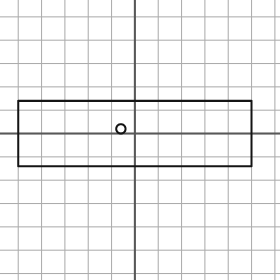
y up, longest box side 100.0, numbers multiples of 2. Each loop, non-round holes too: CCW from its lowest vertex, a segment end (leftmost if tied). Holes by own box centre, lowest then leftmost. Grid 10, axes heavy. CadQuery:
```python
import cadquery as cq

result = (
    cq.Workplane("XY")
    .moveTo(-50.0, -14.0)
    .lineTo(50.0, -14.0)
    .lineTo(50.0, 14.0)
    .lineTo(-50.0, 14.0)
    .close()
    .moveTo(-6.0, 2.0)
    .circle(2.0)
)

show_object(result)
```